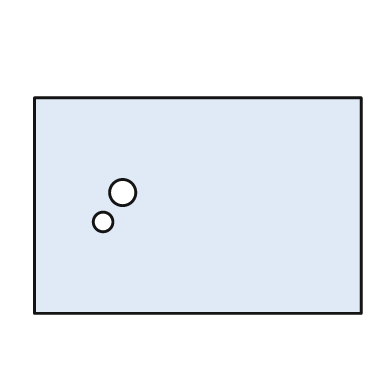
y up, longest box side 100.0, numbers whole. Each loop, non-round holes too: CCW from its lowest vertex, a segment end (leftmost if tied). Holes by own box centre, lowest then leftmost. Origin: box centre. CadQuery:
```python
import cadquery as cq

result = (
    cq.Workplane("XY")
    .moveTo(-50.0, -33.0)
    .lineTo(50.0, -33.0)
    .lineTo(50.0, 33.0)
    .lineTo(-50.0, 33.0)
    .close()
    .moveTo(-29.0, -5.0)
    .circle(3.0)
    .moveTo(-23.0, 4.0)
    .circle(4.0)
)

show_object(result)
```